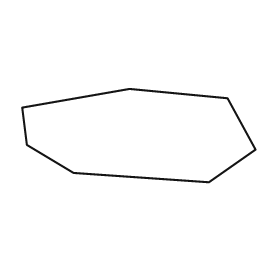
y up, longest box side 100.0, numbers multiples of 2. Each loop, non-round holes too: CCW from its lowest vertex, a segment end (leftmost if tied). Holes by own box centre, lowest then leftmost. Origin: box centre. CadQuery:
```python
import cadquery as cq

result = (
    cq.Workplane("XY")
    .moveTo(30.0, -20.0)
    .lineTo(50.0, -6.0)
    .lineTo(38.0, 16.0)
    .lineTo(-4.0, 20.0)
    .lineTo(-50.0, 12.0)
    .lineTo(-48.0, -4.0)
    .lineTo(-28.0, -16.0)
    .close()
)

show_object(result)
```